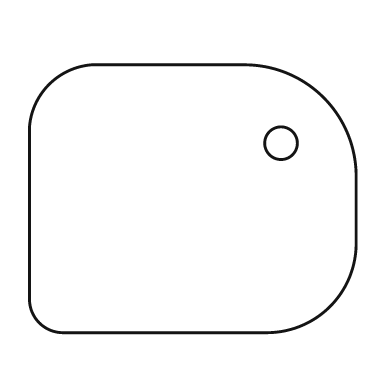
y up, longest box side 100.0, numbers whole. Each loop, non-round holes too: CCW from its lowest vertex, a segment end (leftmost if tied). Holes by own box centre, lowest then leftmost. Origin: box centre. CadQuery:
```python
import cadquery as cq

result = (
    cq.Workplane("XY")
    .moveTo(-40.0, -41.0)
    .lineTo(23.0, -41.0)
    .threePointArc((42.0, -33.0), (50.0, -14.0))
    .lineTo(50.0, 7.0)
    .threePointArc((40.0, 31.0), (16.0, 41.0))
    .lineTo(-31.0, 41.0)
    .threePointArc((-44.0, 35.0), (-50.0, 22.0))
    .lineTo(-50.0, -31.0)
    .threePointArc((-47.0, -38.0), (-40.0, -41.0))
    .close()
    .moveTo(27.0, 17.0)
    .circle(5.0)
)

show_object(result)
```